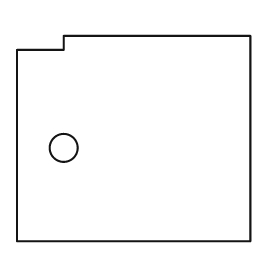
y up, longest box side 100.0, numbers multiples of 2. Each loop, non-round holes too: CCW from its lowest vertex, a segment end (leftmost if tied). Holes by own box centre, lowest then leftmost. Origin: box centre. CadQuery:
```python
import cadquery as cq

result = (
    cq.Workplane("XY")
    .moveTo(-50.0, -44.0)
    .lineTo(50.0, -44.0)
    .lineTo(50.0, 44.0)
    .lineTo(-30.0, 44.0)
    .lineTo(-30.0, 38.0)
    .lineTo(-50.0, 38.0)
    .close()
    .moveTo(-30.0, -4.0)
    .circle(6.0)
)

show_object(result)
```